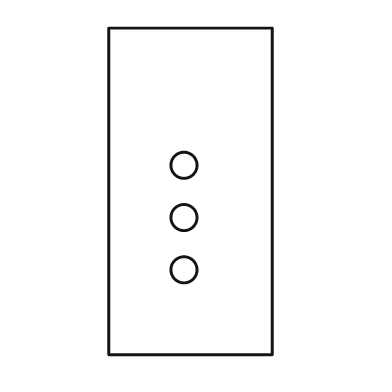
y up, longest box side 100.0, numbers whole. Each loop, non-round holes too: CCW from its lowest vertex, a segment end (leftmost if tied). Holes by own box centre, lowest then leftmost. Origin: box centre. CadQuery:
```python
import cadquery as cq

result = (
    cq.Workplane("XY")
    .moveTo(-25.0, -50.0)
    .lineTo(25.0, -50.0)
    .lineTo(25.0, 50.0)
    .lineTo(-25.0, 50.0)
    .close()
    .moveTo(-2.0, -24.0)
    .circle(4.0)
    .moveTo(-2.0, -8.0)
    .circle(4.0)
    .moveTo(-2.0, 8.0)
    .circle(4.0)
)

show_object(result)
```